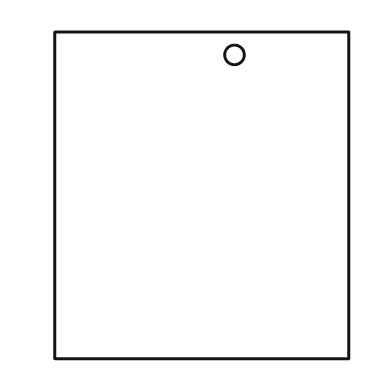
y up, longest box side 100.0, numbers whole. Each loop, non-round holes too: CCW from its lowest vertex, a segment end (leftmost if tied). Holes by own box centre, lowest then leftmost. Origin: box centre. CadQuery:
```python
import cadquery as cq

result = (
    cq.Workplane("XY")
    .moveTo(-45.0, -50.0)
    .lineTo(45.0, -50.0)
    .lineTo(45.0, 50.0)
    .lineTo(-45.0, 50.0)
    .close()
    .moveTo(10.0, 43.0)
    .circle(3.0)
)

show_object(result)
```